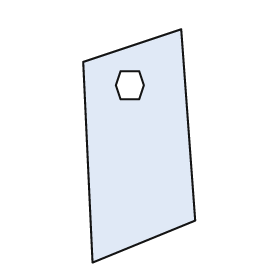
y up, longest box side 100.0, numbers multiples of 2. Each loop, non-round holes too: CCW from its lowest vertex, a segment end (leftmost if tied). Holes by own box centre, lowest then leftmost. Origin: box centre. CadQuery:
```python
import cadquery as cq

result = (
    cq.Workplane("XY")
    .moveTo(-20.0, -50.0)
    .lineTo(24.0, -32.0)
    .lineTo(18.0, 50.0)
    .lineTo(-24.0, 36.0)
    .close()
    .moveTo(-8.0, 20.0)
    .lineTo(0.0, 20.0)
    .lineTo(2.0, 26.0)
    .lineTo(0.0, 32.0)
    .lineTo(-8.0, 32.0)
    .lineTo(-10.0, 26.0)
    .close()
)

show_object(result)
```